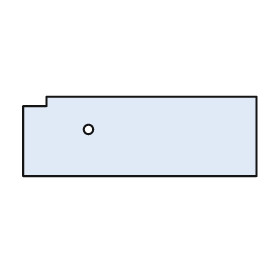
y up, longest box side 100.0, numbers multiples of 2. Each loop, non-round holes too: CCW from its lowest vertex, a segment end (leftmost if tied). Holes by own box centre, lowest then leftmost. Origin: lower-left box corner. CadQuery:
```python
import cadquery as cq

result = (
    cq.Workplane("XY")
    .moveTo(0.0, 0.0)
    .lineTo(100.0, 0.0)
    .lineTo(100.0, 34.0)
    .lineTo(10.0, 34.0)
    .lineTo(10.0, 30.0)
    .lineTo(0.0, 30.0)
    .close()
    .moveTo(28.0, 20.0)
    .circle(2.0)
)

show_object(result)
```